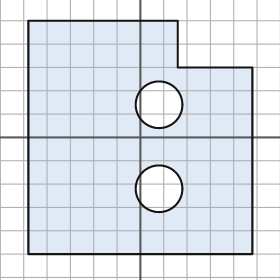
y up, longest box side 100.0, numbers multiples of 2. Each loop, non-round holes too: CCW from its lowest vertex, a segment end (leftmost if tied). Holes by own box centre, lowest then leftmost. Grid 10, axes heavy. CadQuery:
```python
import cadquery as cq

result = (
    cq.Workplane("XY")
    .moveTo(-48.0, -50.0)
    .lineTo(48.0, -50.0)
    .lineTo(48.0, 30.0)
    .lineTo(16.0, 30.0)
    .lineTo(16.0, 50.0)
    .lineTo(-48.0, 50.0)
    .close()
    .moveTo(8.0, -22.0)
    .circle(10.0)
    .moveTo(8.0, 14.0)
    .circle(10.0)
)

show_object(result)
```